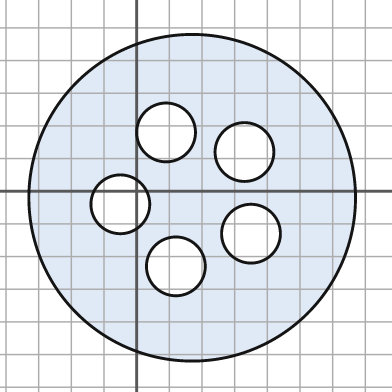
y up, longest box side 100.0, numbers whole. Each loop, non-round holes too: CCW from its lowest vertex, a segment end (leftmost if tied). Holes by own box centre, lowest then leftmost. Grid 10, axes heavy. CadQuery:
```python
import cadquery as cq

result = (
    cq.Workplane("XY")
    .moveTo(17.0, -2.0)
    .circle(50.0)
    .moveTo(12.0, -23.0)
    .circle(9.0)
    .moveTo(35.0, -13.0)
    .circle(9.0)
    .moveTo(-5.0, -4.0)
    .circle(9.0)
    .moveTo(33.0, 12.0)
    .circle(9.0)
    .moveTo(9.0, 18.0)
    .circle(9.0)
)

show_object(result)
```